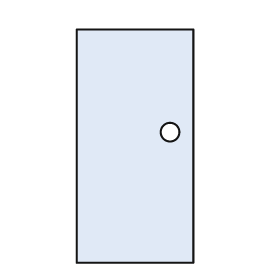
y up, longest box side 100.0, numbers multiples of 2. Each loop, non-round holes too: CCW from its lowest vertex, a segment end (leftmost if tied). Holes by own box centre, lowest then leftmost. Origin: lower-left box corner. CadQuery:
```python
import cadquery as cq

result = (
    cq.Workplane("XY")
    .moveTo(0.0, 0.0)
    .lineTo(50.0, 0.0)
    .lineTo(50.0, 100.0)
    .lineTo(0.0, 100.0)
    .close()
    .moveTo(40.0, 56.0)
    .circle(4.0)
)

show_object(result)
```